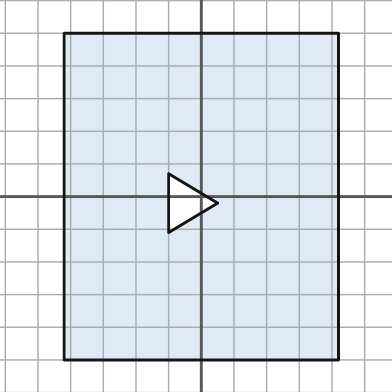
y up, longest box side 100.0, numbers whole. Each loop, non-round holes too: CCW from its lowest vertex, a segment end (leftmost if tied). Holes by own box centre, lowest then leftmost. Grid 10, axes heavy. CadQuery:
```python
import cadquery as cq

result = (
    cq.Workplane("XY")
    .moveTo(-42.0, -50.0)
    .lineTo(42.0, -50.0)
    .lineTo(42.0, 50.0)
    .lineTo(-42.0, 50.0)
    .close()
    .moveTo(-10.0, -11.0)
    .lineTo(5.0, -2.0)
    .lineTo(-10.0, 7.0)
    .close()
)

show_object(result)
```